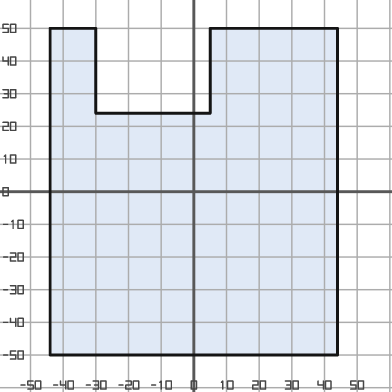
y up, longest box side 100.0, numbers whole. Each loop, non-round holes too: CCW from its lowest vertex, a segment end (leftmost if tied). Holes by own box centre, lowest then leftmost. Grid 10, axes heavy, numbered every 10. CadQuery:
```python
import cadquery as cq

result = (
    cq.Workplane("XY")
    .moveTo(-44.0, -50.0)
    .lineTo(44.0, -50.0)
    .lineTo(44.0, 50.0)
    .lineTo(5.0, 50.0)
    .lineTo(5.0, 24.0)
    .lineTo(-30.0, 24.0)
    .lineTo(-30.0, 50.0)
    .lineTo(-44.0, 50.0)
    .close()
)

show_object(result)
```